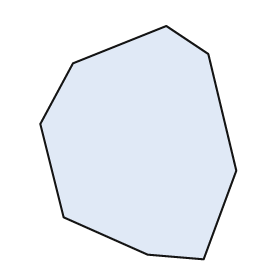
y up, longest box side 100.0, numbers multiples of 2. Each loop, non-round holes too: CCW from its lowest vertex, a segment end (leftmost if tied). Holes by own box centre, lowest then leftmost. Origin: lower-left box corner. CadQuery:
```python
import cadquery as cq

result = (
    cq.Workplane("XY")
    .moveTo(70.0, 0.0)
    .lineTo(84.0, 38.0)
    .lineTo(72.0, 88.0)
    .lineTo(54.0, 100.0)
    .lineTo(14.0, 84.0)
    .lineTo(0.0, 58.0)
    .lineTo(10.0, 18.0)
    .lineTo(46.0, 2.0)
    .close()
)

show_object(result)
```